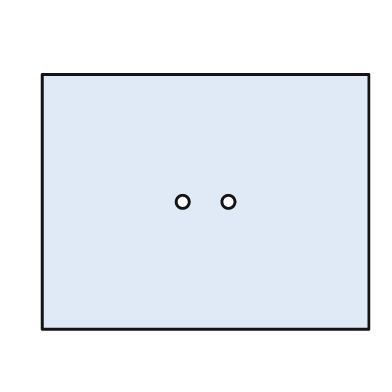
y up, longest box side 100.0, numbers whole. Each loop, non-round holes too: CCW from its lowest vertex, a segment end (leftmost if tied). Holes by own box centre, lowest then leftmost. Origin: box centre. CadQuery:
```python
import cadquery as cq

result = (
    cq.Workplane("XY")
    .moveTo(-50.0, -39.0)
    .lineTo(50.0, -39.0)
    .lineTo(50.0, 39.0)
    .lineTo(-50.0, 39.0)
    .close()
    .moveTo(-7.0, 0.0)
    .circle(2.0)
    .moveTo(7.0, 0.0)
    .circle(2.0)
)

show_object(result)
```